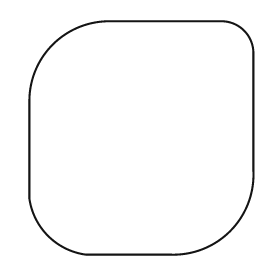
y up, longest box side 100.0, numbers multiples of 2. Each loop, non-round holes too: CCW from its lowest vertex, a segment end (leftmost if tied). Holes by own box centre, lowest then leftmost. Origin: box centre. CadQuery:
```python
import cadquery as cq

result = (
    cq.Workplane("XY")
    .moveTo(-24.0, -50.0)
    .lineTo(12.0, -50.0)
    .threePointArc((38.0, -40.0), (48.0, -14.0))
    .lineTo(48.0, 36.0)
    .threePointArc((44.0, 46.0), (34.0, 50.0))
    .lineTo(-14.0, 50.0)
    .threePointArc((-38.0, 40.0), (-48.0, 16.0))
    .lineTo(-48.0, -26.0)
    .threePointArc((-40.0, -42.0), (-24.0, -50.0))
    .close()
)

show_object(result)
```